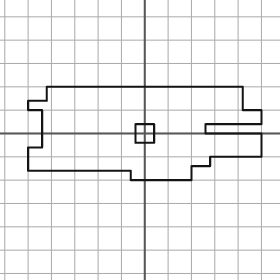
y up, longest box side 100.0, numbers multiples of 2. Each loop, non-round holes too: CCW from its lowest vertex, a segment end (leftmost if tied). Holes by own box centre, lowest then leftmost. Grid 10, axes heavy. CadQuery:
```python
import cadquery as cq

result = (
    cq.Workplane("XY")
    .moveTo(-6.0, -20.0)
    .lineTo(20.0, -20.0)
    .lineTo(20.0, -14.0)
    .lineTo(28.0, -14.0)
    .lineTo(28.0, -10.0)
    .lineTo(50.0, -10.0)
    .lineTo(50.0, 0.0)
    .lineTo(26.0, 0.0)
    .lineTo(26.0, 4.0)
    .lineTo(50.0, 4.0)
    .lineTo(50.0, 10.0)
    .lineTo(42.0, 10.0)
    .lineTo(42.0, 20.0)
    .lineTo(-42.0, 20.0)
    .lineTo(-42.0, 14.0)
    .lineTo(-50.0, 14.0)
    .lineTo(-50.0, 10.0)
    .lineTo(-44.0, 10.0)
    .lineTo(-44.0, -6.0)
    .lineTo(-50.0, -6.0)
    .lineTo(-50.0, -16.0)
    .lineTo(-6.0, -16.0)
    .close()
    .moveTo(-4.0, -4.0)
    .lineTo(4.0, -4.0)
    .lineTo(4.0, 4.0)
    .lineTo(-4.0, 4.0)
    .close()
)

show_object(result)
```